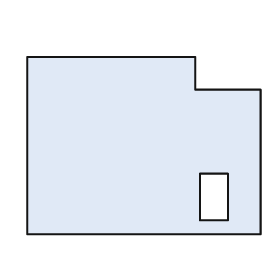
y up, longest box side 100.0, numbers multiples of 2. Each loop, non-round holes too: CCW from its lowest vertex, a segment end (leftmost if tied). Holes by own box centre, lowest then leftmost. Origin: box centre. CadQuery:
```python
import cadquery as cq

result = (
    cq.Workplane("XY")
    .moveTo(-50.0, -38.0)
    .lineTo(50.0, -38.0)
    .lineTo(50.0, 24.0)
    .lineTo(22.0, 24.0)
    .lineTo(22.0, 38.0)
    .lineTo(-50.0, 38.0)
    .close()
    .moveTo(24.0, -32.0)
    .lineTo(36.0, -32.0)
    .lineTo(36.0, -12.0)
    .lineTo(24.0, -12.0)
    .close()
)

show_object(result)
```